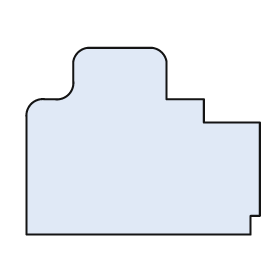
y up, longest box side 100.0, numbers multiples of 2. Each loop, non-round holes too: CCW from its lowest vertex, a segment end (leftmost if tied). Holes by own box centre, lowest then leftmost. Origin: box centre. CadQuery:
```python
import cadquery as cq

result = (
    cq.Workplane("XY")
    .moveTo(-50.0, -40.0)
    .lineTo(46.0, -40.0)
    .lineTo(46.0, -32.0)
    .lineTo(50.0, -32.0)
    .lineTo(50.0, 8.0)
    .lineTo(26.0, 8.0)
    .lineTo(26.0, 18.0)
    .lineTo(10.0, 18.0)
    .lineTo(10.0, 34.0)
    .threePointArc((8.0, 38.0), (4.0, 40.0))
    .lineTo(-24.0, 40.0)
    .threePointArc((-28.0, 38.0), (-30.0, 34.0))
    .lineTo(-30.0, 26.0)
    .threePointArc((-32.0, 20.0), (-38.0, 18.0))
    .lineTo(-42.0, 18.0)
    .threePointArc((-48.0, 16.0), (-50.0, 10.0))
    .close()
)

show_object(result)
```